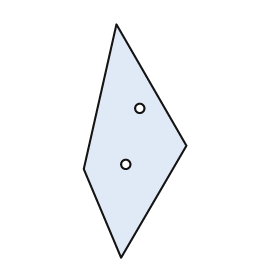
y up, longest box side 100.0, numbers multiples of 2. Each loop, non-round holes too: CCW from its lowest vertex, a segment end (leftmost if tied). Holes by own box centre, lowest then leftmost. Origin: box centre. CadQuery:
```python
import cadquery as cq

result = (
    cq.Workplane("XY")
    .moveTo(-6.0, -50.0)
    .lineTo(22.0, -2.0)
    .lineTo(-8.0, 50.0)
    .lineTo(-22.0, -12.0)
    .close()
    .moveTo(-4.0, -10.0)
    .circle(2.0)
    .moveTo(2.0, 14.0)
    .circle(2.0)
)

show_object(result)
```